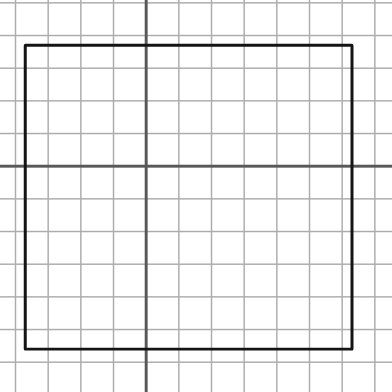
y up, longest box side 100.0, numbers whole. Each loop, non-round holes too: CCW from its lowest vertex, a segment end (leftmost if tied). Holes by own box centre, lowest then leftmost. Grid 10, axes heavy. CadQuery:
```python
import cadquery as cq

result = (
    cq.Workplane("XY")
    .moveTo(-37.0, -56.0)
    .lineTo(63.0, -56.0)
    .lineTo(63.0, 37.0)
    .lineTo(-37.0, 37.0)
    .close()
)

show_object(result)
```